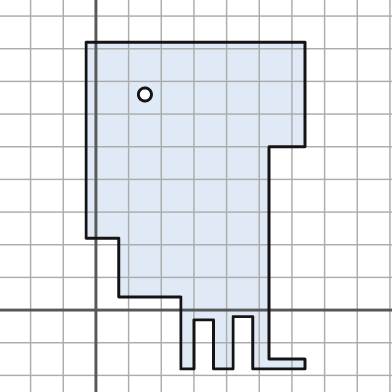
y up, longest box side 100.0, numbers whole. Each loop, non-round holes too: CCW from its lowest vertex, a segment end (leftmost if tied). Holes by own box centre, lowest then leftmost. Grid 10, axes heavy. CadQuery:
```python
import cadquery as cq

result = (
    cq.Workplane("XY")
    .moveTo(26.0, -18.0)
    .lineTo(30.0, -18.0)
    .lineTo(30.0, -3.0)
    .lineTo(36.0, -3.0)
    .lineTo(36.0, -18.0)
    .lineTo(42.0, -18.0)
    .lineTo(42.0, -2.0)
    .lineTo(48.0, -2.0)
    .lineTo(48.0, -18.0)
    .lineTo(64.0, -18.0)
    .lineTo(64.0, -15.0)
    .lineTo(53.0, -15.0)
    .lineTo(53.0, 50.0)
    .lineTo(64.0, 50.0)
    .lineTo(64.0, 82.0)
    .lineTo(-3.0, 82.0)
    .lineTo(-3.0, 22.0)
    .lineTo(7.0, 22.0)
    .lineTo(7.0, 4.0)
    .lineTo(26.0, 4.0)
    .close()
    .moveTo(15.0, 66.0)
    .circle(2.0)
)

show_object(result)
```